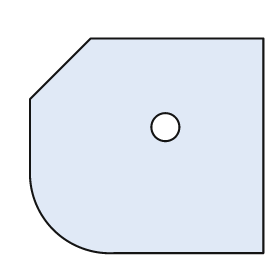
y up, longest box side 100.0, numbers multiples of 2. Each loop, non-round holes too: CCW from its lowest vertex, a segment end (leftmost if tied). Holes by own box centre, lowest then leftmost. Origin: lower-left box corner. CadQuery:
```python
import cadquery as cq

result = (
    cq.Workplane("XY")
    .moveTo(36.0, 0.0)
    .lineTo(100.0, 0.0)
    .lineTo(100.0, 92.0)
    .lineTo(26.0, 92.0)
    .lineTo(0.0, 66.0)
    .lineTo(0.0, 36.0)
    .threePointArc((10.0, 10.0), (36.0, 0.0))
    .close()
    .moveTo(58.0, 54.0)
    .circle(6.0)
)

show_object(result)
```